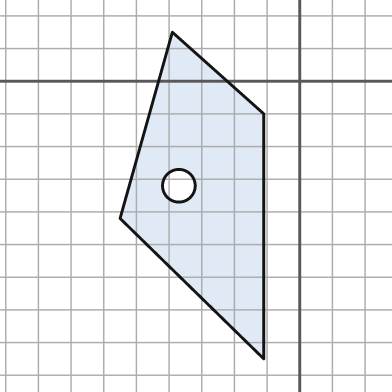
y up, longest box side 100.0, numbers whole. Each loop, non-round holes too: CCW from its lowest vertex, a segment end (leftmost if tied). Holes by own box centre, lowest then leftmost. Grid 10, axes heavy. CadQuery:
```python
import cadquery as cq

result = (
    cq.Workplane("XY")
    .moveTo(-11.0, -85.0)
    .lineTo(-11.0, -10.0)
    .lineTo(-39.0, 15.0)
    .lineTo(-55.0, -42.0)
    .close()
    .moveTo(-37.0, -32.0)
    .circle(5.0)
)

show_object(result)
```